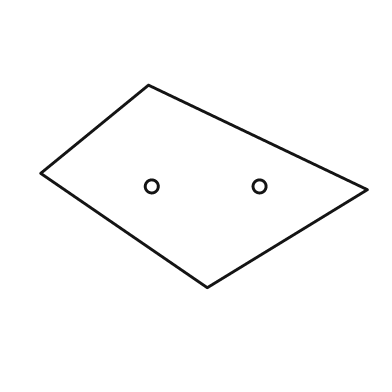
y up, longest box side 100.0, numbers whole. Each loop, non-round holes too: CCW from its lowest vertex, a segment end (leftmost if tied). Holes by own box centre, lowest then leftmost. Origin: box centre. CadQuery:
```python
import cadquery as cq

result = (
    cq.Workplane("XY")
    .moveTo(1.0, -31.0)
    .lineTo(50.0, -1.0)
    .lineTo(-17.0, 31.0)
    .lineTo(-50.0, 4.0)
    .close()
    .moveTo(-16.0, 0.0)
    .circle(2.0)
    .moveTo(17.0, 0.0)
    .circle(2.0)
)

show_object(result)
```